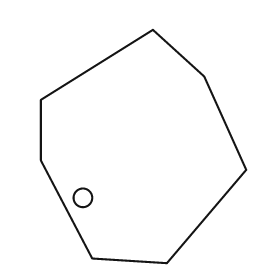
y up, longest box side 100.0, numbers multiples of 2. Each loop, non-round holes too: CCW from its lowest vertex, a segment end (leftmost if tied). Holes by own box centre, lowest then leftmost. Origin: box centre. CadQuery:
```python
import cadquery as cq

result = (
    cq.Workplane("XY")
    .moveTo(10.0, -50.0)
    .lineTo(44.0, -10.0)
    .lineTo(26.0, 30.0)
    .lineTo(4.0, 50.0)
    .lineTo(-44.0, 20.0)
    .lineTo(-44.0, -6.0)
    .lineTo(-22.0, -48.0)
    .close()
    .moveTo(-26.0, -22.0)
    .circle(4.0)
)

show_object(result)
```